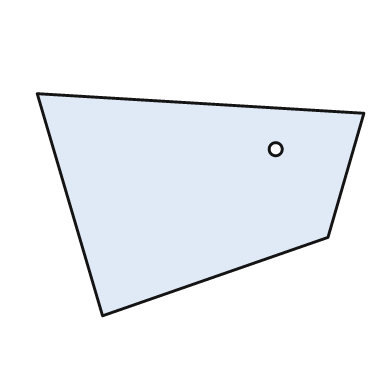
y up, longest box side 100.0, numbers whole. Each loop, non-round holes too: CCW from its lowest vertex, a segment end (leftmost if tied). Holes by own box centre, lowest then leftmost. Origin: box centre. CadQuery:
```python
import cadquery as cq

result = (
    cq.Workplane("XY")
    .moveTo(-30.0, -34.0)
    .lineTo(39.0, -10.0)
    .lineTo(50.0, 28.0)
    .lineTo(-50.0, 34.0)
    .close()
    .moveTo(23.0, 17.0)
    .circle(2.0)
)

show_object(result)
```